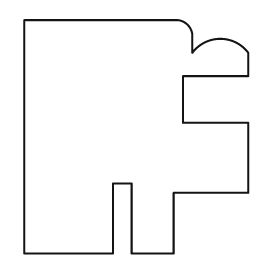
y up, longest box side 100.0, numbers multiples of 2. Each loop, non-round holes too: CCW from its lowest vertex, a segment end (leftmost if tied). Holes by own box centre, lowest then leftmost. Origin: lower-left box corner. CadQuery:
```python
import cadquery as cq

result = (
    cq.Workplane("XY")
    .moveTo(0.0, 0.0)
    .lineTo(38.0, 0.0)
    .lineTo(38.0, 30.0)
    .lineTo(46.0, 30.0)
    .lineTo(46.0, 0.0)
    .lineTo(64.0, 0.0)
    .lineTo(64.0, 26.0)
    .lineTo(96.0, 26.0)
    .lineTo(96.0, 56.0)
    .lineTo(68.0, 56.0)
    .lineTo(68.0, 76.0)
    .lineTo(96.0, 76.0)
    .lineTo(96.0, 86.0)
    .threePointArc((84.0, 92.0), (72.0, 86.0))
    .lineTo(72.0, 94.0)
    .threePointArc((70.0, 98.0), (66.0, 100.0))
    .lineTo(0.0, 100.0)
    .close()
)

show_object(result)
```